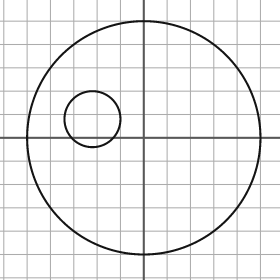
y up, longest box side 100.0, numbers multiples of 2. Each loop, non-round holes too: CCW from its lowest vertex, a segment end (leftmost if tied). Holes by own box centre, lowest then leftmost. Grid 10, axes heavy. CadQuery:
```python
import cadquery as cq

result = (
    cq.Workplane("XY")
    .moveTo(0.0, 0.0)
    .circle(50.0)
    .moveTo(-22.0, 8.0)
    .circle(12.0)
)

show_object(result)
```